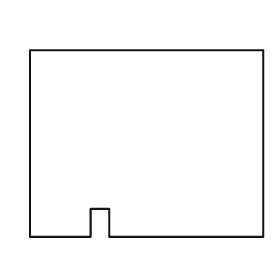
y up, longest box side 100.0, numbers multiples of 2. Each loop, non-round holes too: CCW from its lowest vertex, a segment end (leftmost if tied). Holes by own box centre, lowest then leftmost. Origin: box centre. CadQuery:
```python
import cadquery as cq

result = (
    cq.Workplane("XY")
    .moveTo(-50.0, -40.0)
    .lineTo(-24.0, -40.0)
    .lineTo(-24.0, -28.0)
    .lineTo(-16.0, -28.0)
    .lineTo(-16.0, -40.0)
    .lineTo(50.0, -40.0)
    .lineTo(50.0, 40.0)
    .lineTo(-50.0, 40.0)
    .close()
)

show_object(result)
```